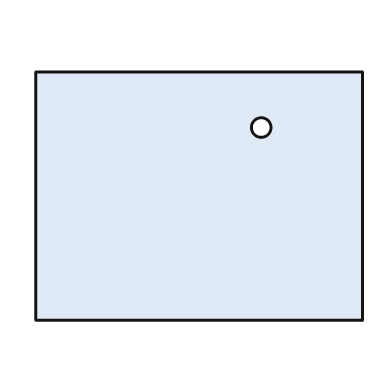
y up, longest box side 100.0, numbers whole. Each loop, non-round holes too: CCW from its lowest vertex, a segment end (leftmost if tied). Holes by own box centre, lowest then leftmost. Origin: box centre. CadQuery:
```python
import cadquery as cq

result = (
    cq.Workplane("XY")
    .moveTo(-50.0, -38.0)
    .lineTo(50.0, -38.0)
    .lineTo(50.0, 38.0)
    .lineTo(-50.0, 38.0)
    .close()
    .moveTo(19.0, 21.0)
    .circle(3.0)
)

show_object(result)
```